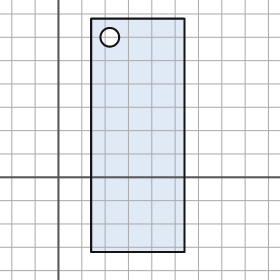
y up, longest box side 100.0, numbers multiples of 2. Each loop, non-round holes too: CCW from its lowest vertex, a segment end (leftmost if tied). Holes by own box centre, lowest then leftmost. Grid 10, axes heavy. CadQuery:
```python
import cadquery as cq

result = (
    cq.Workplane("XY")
    .moveTo(14.0, -32.0)
    .lineTo(54.0, -32.0)
    .lineTo(54.0, 68.0)
    .lineTo(14.0, 68.0)
    .close()
    .moveTo(22.0, 60.0)
    .circle(4.0)
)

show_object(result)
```